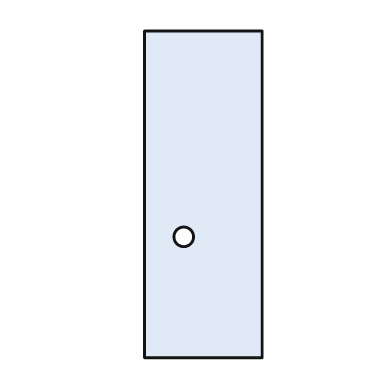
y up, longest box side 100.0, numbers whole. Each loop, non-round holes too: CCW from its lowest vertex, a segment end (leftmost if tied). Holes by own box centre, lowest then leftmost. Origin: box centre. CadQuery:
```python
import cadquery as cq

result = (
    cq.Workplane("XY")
    .moveTo(-18.0, -50.0)
    .lineTo(18.0, -50.0)
    .lineTo(18.0, 50.0)
    .lineTo(-18.0, 50.0)
    .close()
    .moveTo(-6.0, -13.0)
    .circle(3.0)
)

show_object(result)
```